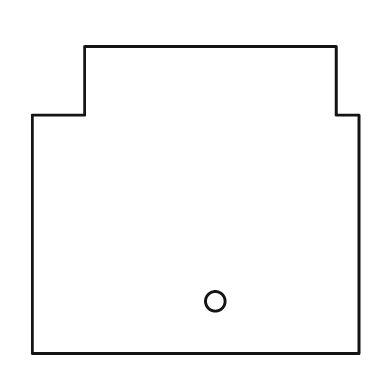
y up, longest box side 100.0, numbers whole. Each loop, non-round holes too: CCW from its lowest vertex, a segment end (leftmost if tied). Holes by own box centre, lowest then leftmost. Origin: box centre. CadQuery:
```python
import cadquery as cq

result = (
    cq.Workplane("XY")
    .moveTo(-50.0, -47.0)
    .lineTo(50.0, -47.0)
    .lineTo(50.0, 26.0)
    .lineTo(43.0, 26.0)
    .lineTo(43.0, 47.0)
    .lineTo(-34.0, 47.0)
    .lineTo(-34.0, 26.0)
    .lineTo(-50.0, 26.0)
    .close()
    .moveTo(6.0, -31.0)
    .circle(3.0)
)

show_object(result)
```